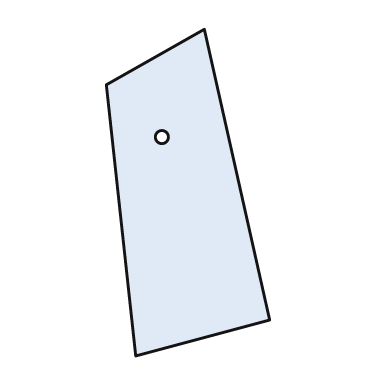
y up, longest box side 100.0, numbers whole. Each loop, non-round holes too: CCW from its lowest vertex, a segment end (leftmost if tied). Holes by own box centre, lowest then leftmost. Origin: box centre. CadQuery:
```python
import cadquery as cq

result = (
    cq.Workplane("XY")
    .moveTo(-16.0, -50.0)
    .lineTo(25.0, -39.0)
    .lineTo(5.0, 50.0)
    .lineTo(-25.0, 33.0)
    .close()
    .moveTo(-8.0, 17.0)
    .circle(2.0)
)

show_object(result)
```